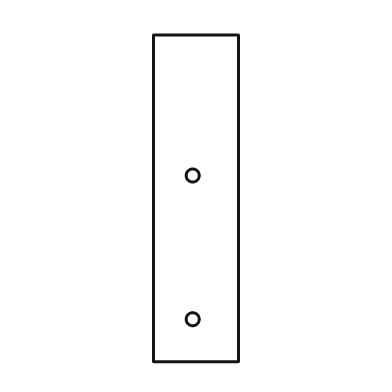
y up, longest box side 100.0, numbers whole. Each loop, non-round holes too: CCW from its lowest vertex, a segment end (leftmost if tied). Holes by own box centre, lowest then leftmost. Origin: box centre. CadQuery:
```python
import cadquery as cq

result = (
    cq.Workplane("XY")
    .moveTo(-13.0, -50.0)
    .lineTo(13.0, -50.0)
    .lineTo(13.0, 50.0)
    .lineTo(-13.0, 50.0)
    .close()
    .moveTo(-1.0, -37.0)
    .circle(2.0)
    .moveTo(-1.0, 7.0)
    .circle(2.0)
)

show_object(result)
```